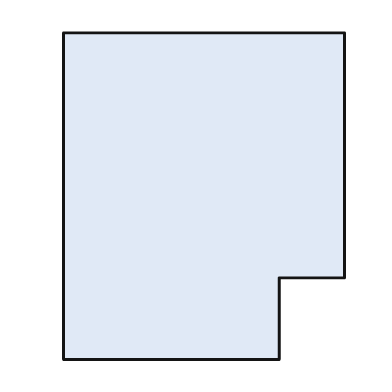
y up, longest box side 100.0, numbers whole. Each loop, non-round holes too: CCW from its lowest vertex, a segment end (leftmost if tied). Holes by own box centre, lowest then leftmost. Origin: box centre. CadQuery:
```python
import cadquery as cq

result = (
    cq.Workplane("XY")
    .moveTo(-43.0, -50.0)
    .lineTo(23.0, -50.0)
    .lineTo(23.0, -25.0)
    .lineTo(43.0, -25.0)
    .lineTo(43.0, 50.0)
    .lineTo(-43.0, 50.0)
    .close()
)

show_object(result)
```